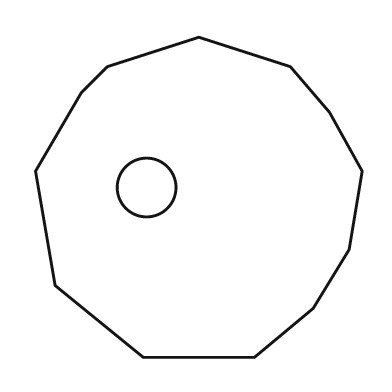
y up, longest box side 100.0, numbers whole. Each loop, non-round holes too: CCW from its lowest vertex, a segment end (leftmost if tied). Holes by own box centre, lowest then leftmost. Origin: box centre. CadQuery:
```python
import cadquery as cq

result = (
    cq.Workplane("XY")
    .moveTo(-17.0, -49.0)
    .lineTo(17.0, -49.0)
    .lineTo(35.0, -34.0)
    .lineTo(46.0, -16.0)
    .lineTo(50.0, 8.0)
    .lineTo(40.0, 26.0)
    .lineTo(28.0, 40.0)
    .lineTo(0.0, 49.0)
    .lineTo(-28.0, 40.0)
    .lineTo(-36.0, 32.0)
    .lineTo(-50.0, 8.0)
    .lineTo(-44.0, -27.0)
    .close()
    .moveTo(-16.0, 3.0)
    .circle(9.0)
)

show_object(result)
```